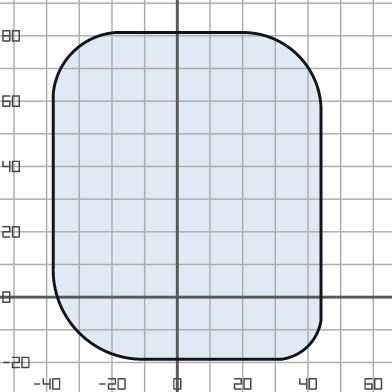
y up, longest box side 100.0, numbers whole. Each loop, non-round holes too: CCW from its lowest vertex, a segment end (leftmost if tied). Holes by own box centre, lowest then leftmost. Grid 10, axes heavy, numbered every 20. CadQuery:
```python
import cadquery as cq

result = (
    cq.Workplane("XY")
    .moveTo(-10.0, -19.0)
    .lineTo(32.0, -19.0)
    .threePointArc((40.0, -15.0), (44.0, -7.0))
    .lineTo(44.0, 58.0)
    .threePointArc((37.0, 74.0), (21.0, 81.0))
    .lineTo(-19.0, 81.0)
    .threePointArc((-32.0, 75.0), (-38.0, 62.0))
    .lineTo(-38.0, 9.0)
    .threePointArc((-30.0, -11.0), (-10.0, -19.0))
    .close()
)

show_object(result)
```